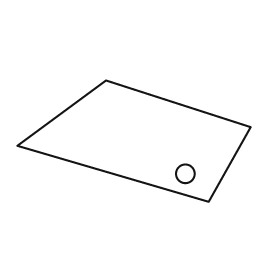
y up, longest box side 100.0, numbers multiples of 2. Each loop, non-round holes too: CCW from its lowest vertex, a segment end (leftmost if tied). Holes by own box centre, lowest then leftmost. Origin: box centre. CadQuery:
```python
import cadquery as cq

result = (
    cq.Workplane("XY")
    .moveTo(32.0, -26.0)
    .lineTo(50.0, 6.0)
    .lineTo(-12.0, 26.0)
    .lineTo(-50.0, -2.0)
    .close()
    .moveTo(22.0, -14.0)
    .circle(4.0)
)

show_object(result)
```